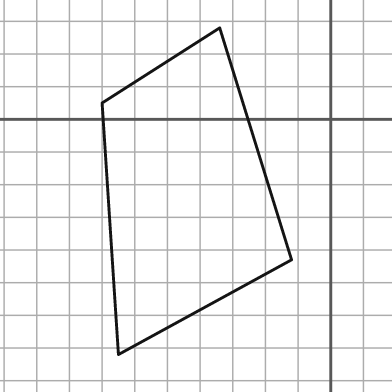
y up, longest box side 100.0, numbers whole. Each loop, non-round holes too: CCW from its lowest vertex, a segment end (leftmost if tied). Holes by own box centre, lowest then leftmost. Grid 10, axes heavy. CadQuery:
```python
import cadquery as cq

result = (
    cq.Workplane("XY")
    .moveTo(-65.0, -72.0)
    .lineTo(-12.0, -43.0)
    .lineTo(-34.0, 28.0)
    .lineTo(-70.0, 5.0)
    .close()
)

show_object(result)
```